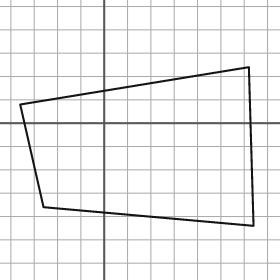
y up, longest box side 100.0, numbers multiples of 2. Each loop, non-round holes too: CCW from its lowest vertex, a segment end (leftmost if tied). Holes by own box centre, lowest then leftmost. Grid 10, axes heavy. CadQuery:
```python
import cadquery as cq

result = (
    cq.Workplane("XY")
    .moveTo(64.0, -44.0)
    .lineTo(62.0, 24.0)
    .lineTo(-36.0, 8.0)
    .lineTo(-26.0, -36.0)
    .close()
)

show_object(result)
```